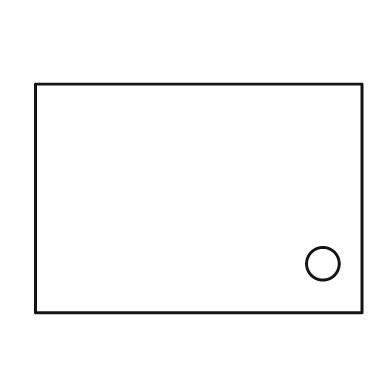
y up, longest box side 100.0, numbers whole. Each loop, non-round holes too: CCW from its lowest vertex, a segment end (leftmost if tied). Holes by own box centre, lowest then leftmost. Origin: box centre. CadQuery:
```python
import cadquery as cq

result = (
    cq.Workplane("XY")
    .moveTo(-50.0, -35.0)
    .lineTo(50.0, -35.0)
    .lineTo(50.0, 35.0)
    .lineTo(-50.0, 35.0)
    .close()
    .moveTo(38.0, -20.0)
    .circle(5.0)
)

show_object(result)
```